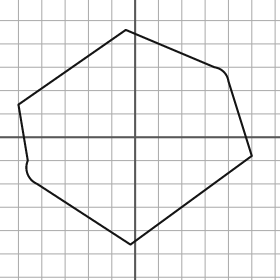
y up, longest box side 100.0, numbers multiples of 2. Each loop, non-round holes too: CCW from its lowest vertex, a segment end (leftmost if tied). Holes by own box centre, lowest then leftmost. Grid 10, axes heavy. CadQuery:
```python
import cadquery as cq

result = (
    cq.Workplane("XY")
    .moveTo(-2.0, -46.0)
    .lineTo(50.0, -8.0)
    .lineTo(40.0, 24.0)
    .threePointArc((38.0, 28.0), (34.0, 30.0))
    .lineTo(-4.0, 46.0)
    .lineTo(-50.0, 14.0)
    .lineTo(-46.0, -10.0)
    .threePointArc((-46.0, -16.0), (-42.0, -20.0))
    .close()
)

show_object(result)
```